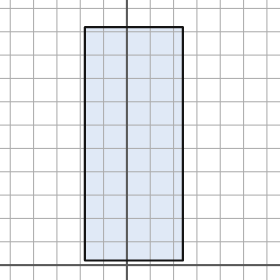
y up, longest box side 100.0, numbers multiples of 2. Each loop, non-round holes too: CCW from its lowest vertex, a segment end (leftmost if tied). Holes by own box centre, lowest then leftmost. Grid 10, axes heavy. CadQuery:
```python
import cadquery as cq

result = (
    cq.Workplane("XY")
    .moveTo(-18.0, 2.0)
    .lineTo(24.0, 2.0)
    .lineTo(24.0, 102.0)
    .lineTo(-18.0, 102.0)
    .close()
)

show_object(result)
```